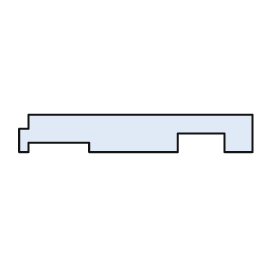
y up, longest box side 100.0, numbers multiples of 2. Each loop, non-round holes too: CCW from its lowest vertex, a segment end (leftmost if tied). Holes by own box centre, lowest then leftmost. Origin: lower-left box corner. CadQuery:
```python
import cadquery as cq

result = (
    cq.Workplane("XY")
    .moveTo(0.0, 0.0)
    .lineTo(4.0, 0.0)
    .lineTo(4.0, 4.0)
    .lineTo(30.0, 4.0)
    .lineTo(30.0, 0.0)
    .lineTo(68.0, 0.0)
    .lineTo(68.0, 8.0)
    .lineTo(88.0, 8.0)
    .lineTo(88.0, 0.0)
    .lineTo(100.0, 0.0)
    .lineTo(100.0, 16.0)
    .lineTo(4.0, 16.0)
    .lineTo(4.0, 10.0)
    .lineTo(0.0, 10.0)
    .close()
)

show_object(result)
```